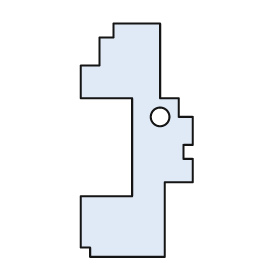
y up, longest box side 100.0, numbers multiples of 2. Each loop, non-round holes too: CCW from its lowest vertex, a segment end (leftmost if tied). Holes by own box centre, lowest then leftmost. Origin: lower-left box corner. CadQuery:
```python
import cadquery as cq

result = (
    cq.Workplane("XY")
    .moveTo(4.0, 0.0)
    .lineTo(36.0, 0.0)
    .lineTo(36.0, 32.0)
    .lineTo(48.0, 32.0)
    .lineTo(48.0, 42.0)
    .lineTo(44.0, 42.0)
    .lineTo(44.0, 48.0)
    .lineTo(48.0, 48.0)
    .lineTo(48.0, 60.0)
    .lineTo(42.0, 60.0)
    .lineTo(42.0, 68.0)
    .lineTo(34.0, 68.0)
    .lineTo(34.0, 100.0)
    .lineTo(14.0, 100.0)
    .lineTo(14.0, 94.0)
    .lineTo(8.0, 94.0)
    .lineTo(8.0, 82.0)
    .lineTo(0.0, 82.0)
    .lineTo(0.0, 68.0)
    .lineTo(22.0, 68.0)
    .lineTo(22.0, 26.0)
    .lineTo(0.0, 26.0)
    .lineTo(0.0, 4.0)
    .lineTo(4.0, 4.0)
    .close()
    .moveTo(34.0, 60.0)
    .circle(4.0)
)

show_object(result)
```